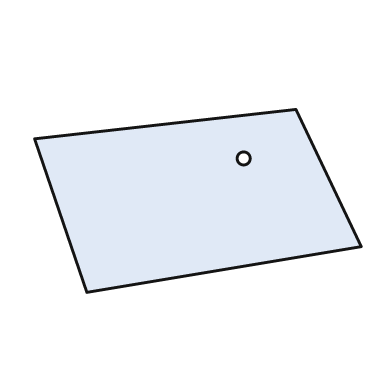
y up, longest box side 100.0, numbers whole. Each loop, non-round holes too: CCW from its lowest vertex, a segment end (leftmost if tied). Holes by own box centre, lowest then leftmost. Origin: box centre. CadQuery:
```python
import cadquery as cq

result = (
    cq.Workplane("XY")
    .moveTo(-34.0, -28.0)
    .lineTo(50.0, -14.0)
    .lineTo(30.0, 28.0)
    .lineTo(-50.0, 19.0)
    .close()
    .moveTo(14.0, 13.0)
    .circle(2.0)
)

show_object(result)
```